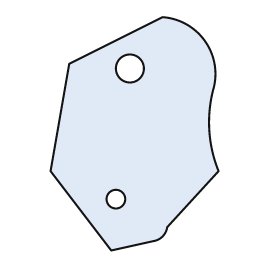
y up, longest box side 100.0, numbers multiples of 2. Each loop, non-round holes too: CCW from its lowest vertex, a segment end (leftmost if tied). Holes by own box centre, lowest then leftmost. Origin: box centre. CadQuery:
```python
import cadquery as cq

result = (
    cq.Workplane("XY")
    .moveTo(-10.0, -50.0)
    .lineTo(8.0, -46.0)
    .threePointArc((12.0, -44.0), (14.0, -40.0))
    .lineTo(36.0, -16.0)
    .threePointArc((32.0, 2.0), (34.0, 20.0))
    .threePointArc((30.0, 40.0), (12.0, 50.0))
    .lineTo(-28.0, 30.0)
    .lineTo(-36.0, -16.0)
    .close()
    .moveTo(-8.0, -28.0)
    .circle(4.0)
    .moveTo(-2.0, 28.0)
    .circle(6.0)
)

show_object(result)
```